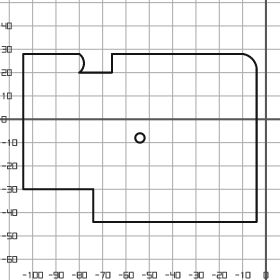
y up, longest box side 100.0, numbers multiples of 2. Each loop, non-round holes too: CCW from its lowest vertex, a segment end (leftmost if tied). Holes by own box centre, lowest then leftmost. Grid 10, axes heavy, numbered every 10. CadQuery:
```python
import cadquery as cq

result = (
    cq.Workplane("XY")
    .moveTo(-74.0, -44.0)
    .lineTo(-4.0, -44.0)
    .lineTo(-4.0, 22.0)
    .threePointArc((-6.0, 26.0), (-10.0, 28.0))
    .lineTo(-66.0, 28.0)
    .lineTo(-66.0, 20.0)
    .lineTo(-80.0, 20.0)
    .threePointArc((-78.0, 24.0), (-80.0, 28.0))
    .lineTo(-104.0, 28.0)
    .lineTo(-104.0, -30.0)
    .lineTo(-74.0, -30.0)
    .close()
    .moveTo(-54.0, -8.0)
    .circle(2.0)
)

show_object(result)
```